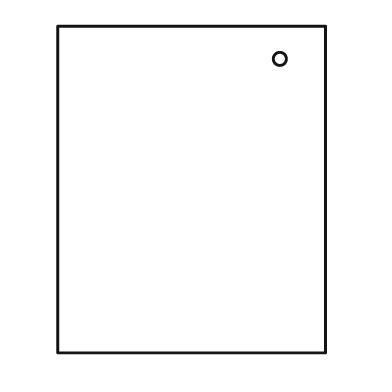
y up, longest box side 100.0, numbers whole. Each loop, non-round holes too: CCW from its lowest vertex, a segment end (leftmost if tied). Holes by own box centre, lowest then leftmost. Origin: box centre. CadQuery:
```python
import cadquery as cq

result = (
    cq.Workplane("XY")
    .moveTo(-41.0, -50.0)
    .lineTo(41.0, -50.0)
    .lineTo(41.0, 50.0)
    .lineTo(-41.0, 50.0)
    .close()
    .moveTo(27.0, 40.0)
    .circle(2.0)
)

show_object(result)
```